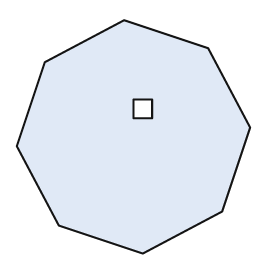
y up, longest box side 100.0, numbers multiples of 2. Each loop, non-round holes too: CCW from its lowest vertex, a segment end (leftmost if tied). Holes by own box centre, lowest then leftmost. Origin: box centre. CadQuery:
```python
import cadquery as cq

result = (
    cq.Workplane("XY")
    .moveTo(4.0, -50.0)
    .lineTo(38.0, -32.0)
    .lineTo(50.0, 4.0)
    .lineTo(32.0, 38.0)
    .lineTo(-4.0, 50.0)
    .lineTo(-38.0, 32.0)
    .lineTo(-50.0, -4.0)
    .lineTo(-32.0, -38.0)
    .close()
    .moveTo(0.0, 8.0)
    .lineTo(8.0, 8.0)
    .lineTo(8.0, 16.0)
    .lineTo(0.0, 16.0)
    .close()
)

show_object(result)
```